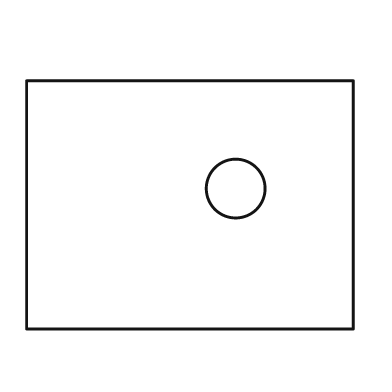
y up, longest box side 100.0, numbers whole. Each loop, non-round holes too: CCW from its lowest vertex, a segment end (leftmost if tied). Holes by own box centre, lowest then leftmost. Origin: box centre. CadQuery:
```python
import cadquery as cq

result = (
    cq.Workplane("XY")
    .moveTo(-50.0, -38.0)
    .lineTo(50.0, -38.0)
    .lineTo(50.0, 38.0)
    .lineTo(-50.0, 38.0)
    .close()
    .moveTo(14.0, 5.0)
    .circle(9.0)
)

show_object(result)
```